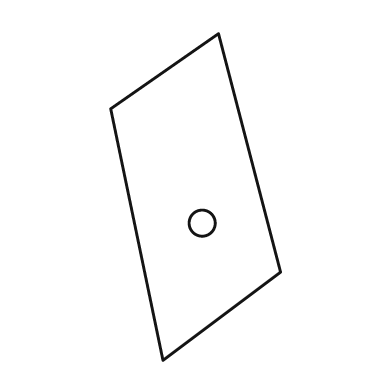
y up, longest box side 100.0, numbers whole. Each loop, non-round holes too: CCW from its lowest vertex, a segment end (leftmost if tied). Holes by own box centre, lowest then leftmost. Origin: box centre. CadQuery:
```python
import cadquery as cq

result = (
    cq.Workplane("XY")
    .moveTo(-10.0, -50.0)
    .lineTo(26.0, -23.0)
    .lineTo(7.0, 50.0)
    .lineTo(-26.0, 27.0)
    .close()
    .moveTo(2.0, -8.0)
    .circle(4.0)
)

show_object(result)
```